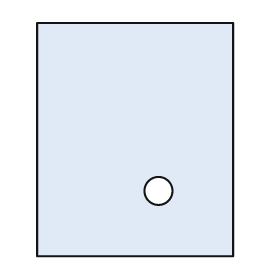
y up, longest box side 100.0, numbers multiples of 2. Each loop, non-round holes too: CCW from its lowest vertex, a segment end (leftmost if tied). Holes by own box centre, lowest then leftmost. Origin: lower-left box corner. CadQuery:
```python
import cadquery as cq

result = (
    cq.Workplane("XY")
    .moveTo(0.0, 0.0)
    .lineTo(84.0, 0.0)
    .lineTo(84.0, 100.0)
    .lineTo(0.0, 100.0)
    .close()
    .moveTo(52.0, 28.0)
    .circle(6.0)
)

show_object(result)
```